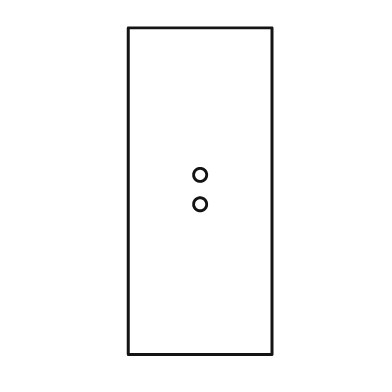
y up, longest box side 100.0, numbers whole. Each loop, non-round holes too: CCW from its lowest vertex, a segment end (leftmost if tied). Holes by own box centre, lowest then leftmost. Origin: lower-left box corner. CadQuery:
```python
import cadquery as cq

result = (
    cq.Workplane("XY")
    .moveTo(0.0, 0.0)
    .lineTo(44.0, 0.0)
    .lineTo(44.0, 100.0)
    .lineTo(0.0, 100.0)
    .close()
    .moveTo(22.0, 46.0)
    .circle(2.0)
    .moveTo(22.0, 55.0)
    .circle(2.0)
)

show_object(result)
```